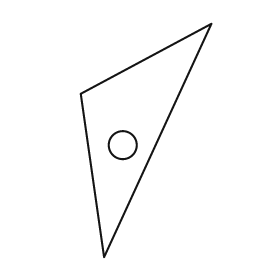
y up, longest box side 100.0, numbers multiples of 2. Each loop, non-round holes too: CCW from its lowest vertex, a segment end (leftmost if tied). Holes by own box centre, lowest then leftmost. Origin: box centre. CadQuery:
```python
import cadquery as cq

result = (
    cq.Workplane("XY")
    .moveTo(-18.0, -50.0)
    .lineTo(28.0, 50.0)
    .lineTo(-28.0, 20.0)
    .close()
    .moveTo(-10.0, -2.0)
    .circle(6.0)
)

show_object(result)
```